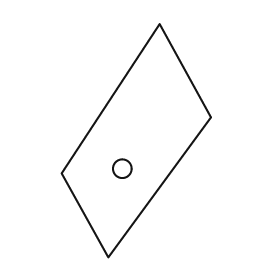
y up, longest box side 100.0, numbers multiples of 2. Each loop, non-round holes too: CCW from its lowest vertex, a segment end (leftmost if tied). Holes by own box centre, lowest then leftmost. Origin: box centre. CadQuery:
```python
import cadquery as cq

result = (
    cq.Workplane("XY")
    .moveTo(-12.0, -50.0)
    .lineTo(32.0, 10.0)
    .lineTo(10.0, 50.0)
    .lineTo(-32.0, -14.0)
    .close()
    .moveTo(-6.0, -12.0)
    .circle(4.0)
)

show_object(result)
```